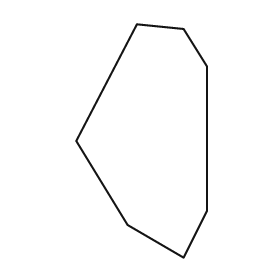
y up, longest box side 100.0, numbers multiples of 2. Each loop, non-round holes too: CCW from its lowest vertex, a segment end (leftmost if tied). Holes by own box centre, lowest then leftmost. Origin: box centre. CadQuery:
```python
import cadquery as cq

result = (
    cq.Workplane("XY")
    .moveTo(18.0, -50.0)
    .lineTo(28.0, -30.0)
    .lineTo(28.0, 32.0)
    .lineTo(18.0, 48.0)
    .lineTo(-2.0, 50.0)
    .lineTo(-28.0, 0.0)
    .lineTo(-6.0, -36.0)
    .close()
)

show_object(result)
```